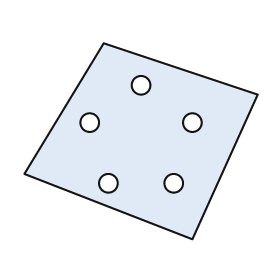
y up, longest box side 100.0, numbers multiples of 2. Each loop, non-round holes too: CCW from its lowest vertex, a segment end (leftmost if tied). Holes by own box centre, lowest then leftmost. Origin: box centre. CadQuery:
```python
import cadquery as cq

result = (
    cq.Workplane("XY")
    .moveTo(22.0, -42.0)
    .lineTo(50.0, 20.0)
    .lineTo(-16.0, 42.0)
    .lineTo(-50.0, -14.0)
    .close()
    .moveTo(-14.0, -18.0)
    .circle(4.0)
    .moveTo(14.0, -18.0)
    .circle(4.0)
    .moveTo(-22.0, 8.0)
    .circle(4.0)
    .moveTo(22.0, 8.0)
    .circle(4.0)
    .moveTo(0.0, 24.0)
    .circle(4.0)
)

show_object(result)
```